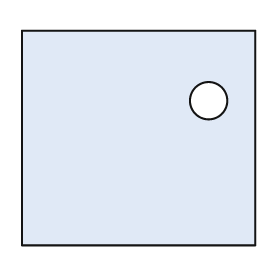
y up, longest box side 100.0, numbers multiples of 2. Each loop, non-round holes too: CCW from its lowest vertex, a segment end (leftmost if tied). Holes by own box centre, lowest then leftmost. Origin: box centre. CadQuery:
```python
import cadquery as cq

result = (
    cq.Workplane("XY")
    .moveTo(-50.0, -46.0)
    .lineTo(50.0, -46.0)
    .lineTo(50.0, 46.0)
    .lineTo(-50.0, 46.0)
    .close()
    .moveTo(30.0, 16.0)
    .circle(8.0)
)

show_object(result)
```